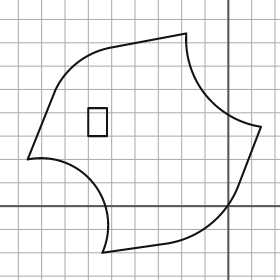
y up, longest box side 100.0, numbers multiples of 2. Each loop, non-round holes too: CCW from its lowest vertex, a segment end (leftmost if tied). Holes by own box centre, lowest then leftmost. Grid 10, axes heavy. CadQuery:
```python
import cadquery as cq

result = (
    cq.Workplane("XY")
    .moveTo(-54.0, -20.0)
    .lineTo(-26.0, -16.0)
    .threePointArc((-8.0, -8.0), (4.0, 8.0))
    .lineTo(14.0, 34.0)
    .threePointArc((-10.0, 48.0), (-18.0, 74.0))
    .lineTo(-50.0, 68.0)
    .threePointArc((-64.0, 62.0), (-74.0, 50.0))
    .lineTo(-86.0, 20.0)
    .threePointArc((-58.0, 10.0), (-54.0, -20.0))
    .close()
    .moveTo(-60.0, 30.0)
    .lineTo(-52.0, 30.0)
    .lineTo(-52.0, 42.0)
    .lineTo(-60.0, 42.0)
    .close()
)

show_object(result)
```